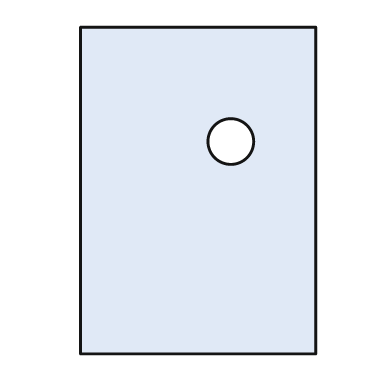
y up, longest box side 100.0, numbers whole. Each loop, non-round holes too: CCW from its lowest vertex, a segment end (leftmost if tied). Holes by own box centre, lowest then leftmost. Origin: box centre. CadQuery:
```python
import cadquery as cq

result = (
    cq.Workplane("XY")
    .moveTo(-36.0, -50.0)
    .lineTo(36.0, -50.0)
    .lineTo(36.0, 50.0)
    .lineTo(-36.0, 50.0)
    .close()
    .moveTo(10.0, 15.0)
    .circle(7.0)
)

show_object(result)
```